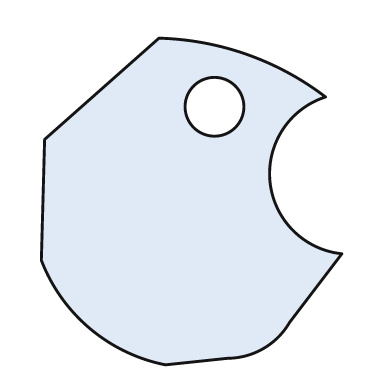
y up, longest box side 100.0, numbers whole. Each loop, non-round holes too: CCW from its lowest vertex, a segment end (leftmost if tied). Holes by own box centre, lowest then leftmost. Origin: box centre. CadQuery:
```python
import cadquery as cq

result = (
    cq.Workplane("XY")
    .moveTo(-8.0, -50.0)
    .lineTo(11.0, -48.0)
    .threePointArc((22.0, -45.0), (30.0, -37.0))
    .lineTo(46.0, -16.0)
    .threePointArc((24.0, 6.0), (41.0, 32.0))
    .threePointArc((17.0, 45.0), (-10.0, 50.0))
    .lineTo(-45.0, 19.0)
    .lineTo(-46.0, -18.0)
    .threePointArc((-31.0, -39.0), (-8.0, -50.0))
    .close()
    .moveTo(7.0, 29.0)
    .circle(9.0)
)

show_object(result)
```